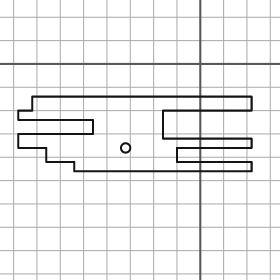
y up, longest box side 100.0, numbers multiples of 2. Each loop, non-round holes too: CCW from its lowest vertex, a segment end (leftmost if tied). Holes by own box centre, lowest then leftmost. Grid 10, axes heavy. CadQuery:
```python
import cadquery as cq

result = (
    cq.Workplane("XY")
    .moveTo(-54.0, -46.0)
    .lineTo(22.0, -46.0)
    .lineTo(22.0, -42.0)
    .lineTo(-10.0, -42.0)
    .lineTo(-10.0, -36.0)
    .lineTo(22.0, -36.0)
    .lineTo(22.0, -32.0)
    .lineTo(-16.0, -32.0)
    .lineTo(-16.0, -20.0)
    .lineTo(22.0, -20.0)
    .lineTo(22.0, -14.0)
    .lineTo(-72.0, -14.0)
    .lineTo(-72.0, -20.0)
    .lineTo(-78.0, -20.0)
    .lineTo(-78.0, -24.0)
    .lineTo(-46.0, -24.0)
    .lineTo(-46.0, -30.0)
    .lineTo(-78.0, -30.0)
    .lineTo(-78.0, -36.0)
    .lineTo(-66.0, -36.0)
    .lineTo(-66.0, -42.0)
    .lineTo(-54.0, -42.0)
    .close()
    .moveTo(-32.0, -36.0)
    .circle(2.0)
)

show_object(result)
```